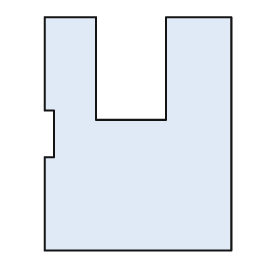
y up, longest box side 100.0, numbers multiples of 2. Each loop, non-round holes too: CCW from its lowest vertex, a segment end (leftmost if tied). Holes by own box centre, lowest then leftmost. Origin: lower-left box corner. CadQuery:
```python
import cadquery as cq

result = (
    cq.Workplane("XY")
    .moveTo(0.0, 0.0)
    .lineTo(80.0, 0.0)
    .lineTo(80.0, 100.0)
    .lineTo(52.0, 100.0)
    .lineTo(52.0, 56.0)
    .lineTo(22.0, 56.0)
    .lineTo(22.0, 100.0)
    .lineTo(0.0, 100.0)
    .lineTo(0.0, 60.0)
    .lineTo(4.0, 60.0)
    .lineTo(4.0, 40.0)
    .lineTo(0.0, 40.0)
    .close()
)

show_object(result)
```